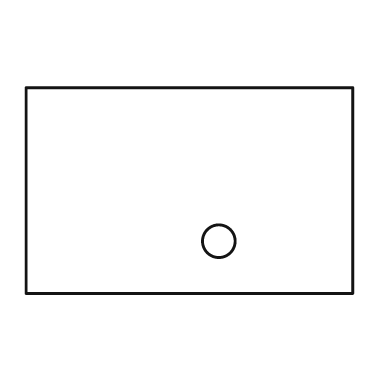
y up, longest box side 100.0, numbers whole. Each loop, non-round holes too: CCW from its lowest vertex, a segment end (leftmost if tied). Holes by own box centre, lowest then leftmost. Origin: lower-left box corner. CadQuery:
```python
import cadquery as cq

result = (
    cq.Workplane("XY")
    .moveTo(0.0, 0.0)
    .lineTo(100.0, 0.0)
    .lineTo(100.0, 63.0)
    .lineTo(0.0, 63.0)
    .close()
    .moveTo(59.0, 16.0)
    .circle(5.0)
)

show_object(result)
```